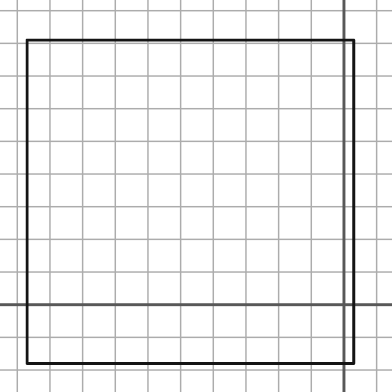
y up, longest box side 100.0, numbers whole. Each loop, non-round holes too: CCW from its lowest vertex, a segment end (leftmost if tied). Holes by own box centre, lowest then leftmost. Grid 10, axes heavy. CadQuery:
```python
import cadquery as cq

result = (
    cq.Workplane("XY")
    .moveTo(-97.0, -18.0)
    .lineTo(3.0, -18.0)
    .lineTo(3.0, 81.0)
    .lineTo(-97.0, 81.0)
    .close()
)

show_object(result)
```